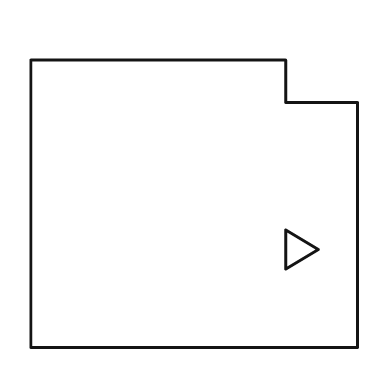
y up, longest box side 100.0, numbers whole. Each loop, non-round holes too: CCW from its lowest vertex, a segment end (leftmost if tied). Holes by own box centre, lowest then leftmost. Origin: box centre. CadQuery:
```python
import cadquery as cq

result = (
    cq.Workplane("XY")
    .moveTo(-50.0, -44.0)
    .lineTo(50.0, -44.0)
    .lineTo(50.0, 31.0)
    .lineTo(28.0, 31.0)
    .lineTo(28.0, 44.0)
    .lineTo(-50.0, 44.0)
    .close()
    .moveTo(28.0, -20.0)
    .lineTo(38.0, -14.0)
    .lineTo(28.0, -8.0)
    .close()
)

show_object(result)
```